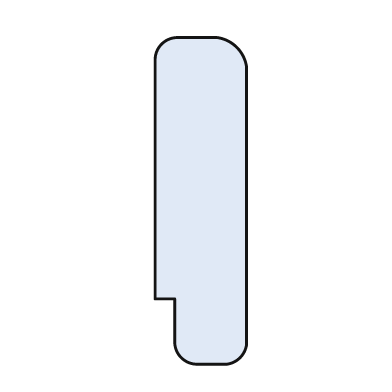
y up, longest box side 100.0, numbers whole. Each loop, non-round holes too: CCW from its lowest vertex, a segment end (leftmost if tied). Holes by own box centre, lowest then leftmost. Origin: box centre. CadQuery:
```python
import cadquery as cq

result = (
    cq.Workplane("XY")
    .moveTo(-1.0, -50.0)
    .lineTo(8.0, -50.0)
    .threePointArc((12.0, -48.0), (14.0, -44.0))
    .lineTo(14.0, 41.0)
    .threePointArc((11.0, 47.0), (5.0, 50.0))
    .lineTo(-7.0, 50.0)
    .threePointArc((-12.0, 48.0), (-14.0, 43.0))
    .lineTo(-14.0, -30.0)
    .lineTo(-8.0, -30.0)
    .lineTo(-8.0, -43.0)
    .threePointArc((-6.0, -48.0), (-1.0, -50.0))
    .close()
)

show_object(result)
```